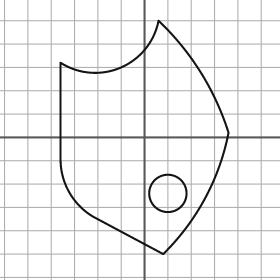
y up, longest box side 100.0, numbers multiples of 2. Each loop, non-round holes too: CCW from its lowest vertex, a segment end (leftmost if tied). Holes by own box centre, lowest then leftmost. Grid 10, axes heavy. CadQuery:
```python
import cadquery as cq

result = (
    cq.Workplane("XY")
    .moveTo(8.0, -50.0)
    .threePointArc((26.0, -26.0), (36.0, 2.0))
    .threePointArc((24.0, 28.0), (6.0, 50.0))
    .threePointArc((-10.0, 30.0), (-36.0, 32.0))
    .lineTo(-36.0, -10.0)
    .threePointArc((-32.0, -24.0), (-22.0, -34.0))
    .close()
    .moveTo(10.0, -24.0)
    .circle(8.0)
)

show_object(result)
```